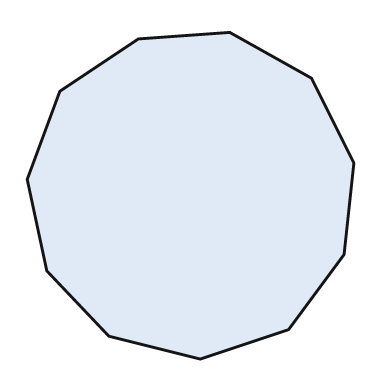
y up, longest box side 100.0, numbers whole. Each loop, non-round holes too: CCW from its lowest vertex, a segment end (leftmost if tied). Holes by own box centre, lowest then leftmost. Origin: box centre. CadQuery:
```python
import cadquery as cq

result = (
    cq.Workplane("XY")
    .moveTo(3.0, -50.0)
    .lineTo(30.0, -41.0)
    .lineTo(47.0, -18.0)
    .lineTo(50.0, 10.0)
    .lineTo(37.0, 36.0)
    .lineTo(12.0, 50.0)
    .lineTo(-16.0, 48.0)
    .lineTo(-40.0, 32.0)
    .lineTo(-50.0, 5.0)
    .lineTo(-44.0, -23.0)
    .lineTo(-25.0, -43.0)
    .close()
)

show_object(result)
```